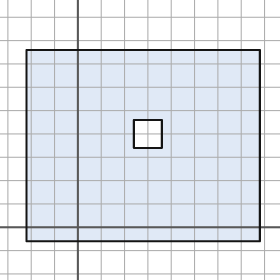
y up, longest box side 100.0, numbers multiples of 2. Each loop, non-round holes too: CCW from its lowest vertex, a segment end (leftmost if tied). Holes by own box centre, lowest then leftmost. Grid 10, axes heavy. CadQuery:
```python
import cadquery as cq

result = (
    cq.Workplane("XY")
    .moveTo(-22.0, -6.0)
    .lineTo(78.0, -6.0)
    .lineTo(78.0, 76.0)
    .lineTo(-22.0, 76.0)
    .close()
    .moveTo(24.0, 34.0)
    .lineTo(36.0, 34.0)
    .lineTo(36.0, 46.0)
    .lineTo(24.0, 46.0)
    .close()
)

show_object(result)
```